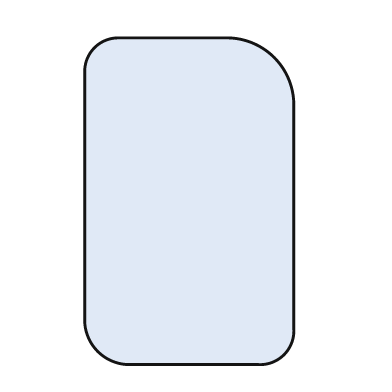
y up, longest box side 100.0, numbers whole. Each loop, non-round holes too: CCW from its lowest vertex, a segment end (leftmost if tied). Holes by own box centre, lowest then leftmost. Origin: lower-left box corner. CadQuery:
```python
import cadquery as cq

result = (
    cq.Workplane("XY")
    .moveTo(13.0, 0.0)
    .lineTo(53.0, 0.0)
    .threePointArc((61.0, 3.0), (64.0, 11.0))
    .lineTo(64.0, 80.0)
    .threePointArc((58.0, 94.0), (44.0, 100.0))
    .lineTo(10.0, 100.0)
    .threePointArc((3.0, 97.0), (0.0, 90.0))
    .lineTo(0.0, 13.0)
    .threePointArc((4.0, 4.0), (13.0, 0.0))
    .close()
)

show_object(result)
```